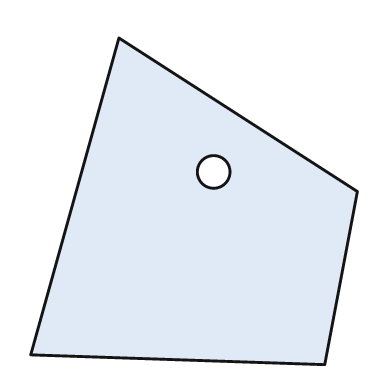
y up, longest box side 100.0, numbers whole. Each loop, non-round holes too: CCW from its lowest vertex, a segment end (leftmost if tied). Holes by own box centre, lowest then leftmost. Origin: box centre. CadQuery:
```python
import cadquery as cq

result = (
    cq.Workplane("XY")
    .moveTo(40.0, -50.0)
    .lineTo(50.0, 3.0)
    .lineTo(-23.0, 50.0)
    .lineTo(-50.0, -47.0)
    .close()
    .moveTo(6.0, 9.0)
    .circle(5.0)
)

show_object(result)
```